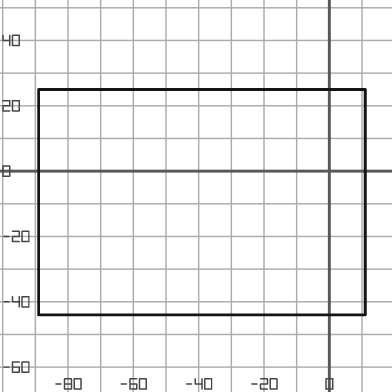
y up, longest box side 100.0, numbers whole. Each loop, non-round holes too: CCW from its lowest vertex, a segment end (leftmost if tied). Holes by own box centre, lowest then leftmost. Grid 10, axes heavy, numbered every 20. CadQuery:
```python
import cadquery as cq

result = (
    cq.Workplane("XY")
    .moveTo(-89.0, -44.0)
    .lineTo(11.0, -44.0)
    .lineTo(11.0, 25.0)
    .lineTo(-89.0, 25.0)
    .close()
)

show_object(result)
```